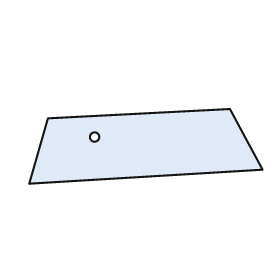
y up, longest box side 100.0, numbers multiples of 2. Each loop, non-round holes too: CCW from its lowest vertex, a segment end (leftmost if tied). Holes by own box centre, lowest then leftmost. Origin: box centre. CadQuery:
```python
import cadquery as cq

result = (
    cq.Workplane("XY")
    .moveTo(-50.0, -16.0)
    .lineTo(50.0, -10.0)
    .lineTo(36.0, 16.0)
    .lineTo(-42.0, 12.0)
    .close()
    .moveTo(-22.0, 4.0)
    .circle(2.0)
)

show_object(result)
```